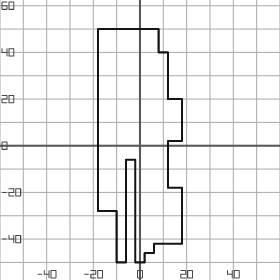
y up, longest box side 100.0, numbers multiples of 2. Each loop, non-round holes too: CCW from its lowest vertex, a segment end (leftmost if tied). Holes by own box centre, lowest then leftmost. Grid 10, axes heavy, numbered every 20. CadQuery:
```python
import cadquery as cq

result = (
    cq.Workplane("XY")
    .moveTo(-10.0, -50.0)
    .lineTo(-6.0, -50.0)
    .lineTo(-6.0, -6.0)
    .lineTo(-2.0, -6.0)
    .lineTo(-2.0, -50.0)
    .lineTo(2.0, -50.0)
    .lineTo(2.0, -46.0)
    .lineTo(6.0, -46.0)
    .lineTo(6.0, -42.0)
    .lineTo(18.0, -42.0)
    .lineTo(18.0, -18.0)
    .lineTo(12.0, -18.0)
    .lineTo(12.0, 2.0)
    .lineTo(18.0, 2.0)
    .lineTo(18.0, 20.0)
    .lineTo(12.0, 20.0)
    .lineTo(12.0, 40.0)
    .lineTo(8.0, 40.0)
    .lineTo(8.0, 50.0)
    .lineTo(-18.0, 50.0)
    .lineTo(-18.0, -28.0)
    .lineTo(-10.0, -28.0)
    .close()
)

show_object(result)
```